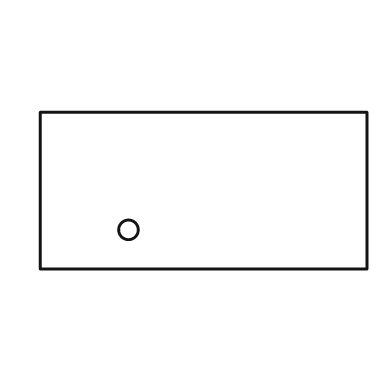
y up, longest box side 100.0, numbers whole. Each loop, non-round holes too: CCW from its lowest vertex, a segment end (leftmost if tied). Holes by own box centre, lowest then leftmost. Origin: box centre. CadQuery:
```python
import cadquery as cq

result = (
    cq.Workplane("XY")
    .moveTo(-50.0, -24.0)
    .lineTo(50.0, -24.0)
    .lineTo(50.0, 24.0)
    .lineTo(-50.0, 24.0)
    .close()
    .moveTo(-23.0, -12.0)
    .circle(3.0)
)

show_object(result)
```